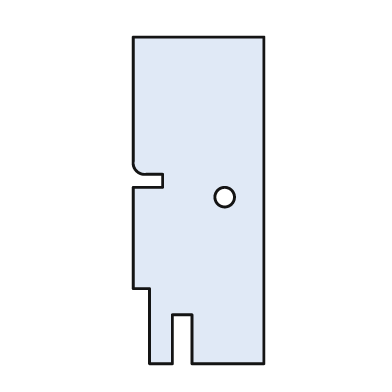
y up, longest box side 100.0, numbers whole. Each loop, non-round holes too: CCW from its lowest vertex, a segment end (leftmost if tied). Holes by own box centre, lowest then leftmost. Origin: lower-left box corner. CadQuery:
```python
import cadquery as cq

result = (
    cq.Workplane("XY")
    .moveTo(5.0, 0.0)
    .lineTo(12.0, 0.0)
    .lineTo(12.0, 15.0)
    .lineTo(18.0, 15.0)
    .lineTo(18.0, 0.0)
    .lineTo(40.0, 0.0)
    .lineTo(40.0, 100.0)
    .lineTo(0.0, 100.0)
    .lineTo(0.0, 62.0)
    .threePointArc((1.0, 59.0), (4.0, 58.0))
    .lineTo(9.0, 58.0)
    .lineTo(9.0, 54.0)
    .lineTo(0.0, 54.0)
    .lineTo(0.0, 23.0)
    .lineTo(5.0, 23.0)
    .close()
    .moveTo(28.0, 51.0)
    .circle(3.0)
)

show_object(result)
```